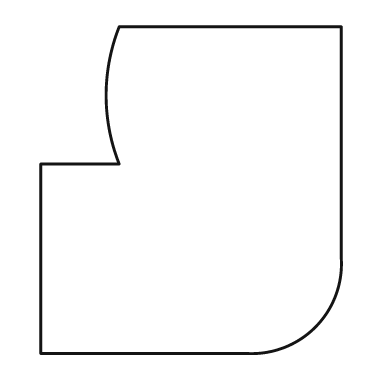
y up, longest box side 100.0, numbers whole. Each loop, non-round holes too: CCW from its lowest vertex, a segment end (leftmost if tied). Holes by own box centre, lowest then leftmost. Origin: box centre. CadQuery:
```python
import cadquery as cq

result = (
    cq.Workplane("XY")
    .moveTo(-46.0, -50.0)
    .lineTo(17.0, -50.0)
    .threePointArc((38.0, -42.0), (46.0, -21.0))
    .lineTo(46.0, 50.0)
    .lineTo(-22.0, 50.0)
    .threePointArc((-26.0, 29.0), (-22.0, 8.0))
    .lineTo(-46.0, 8.0)
    .close()
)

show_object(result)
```